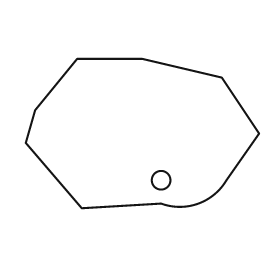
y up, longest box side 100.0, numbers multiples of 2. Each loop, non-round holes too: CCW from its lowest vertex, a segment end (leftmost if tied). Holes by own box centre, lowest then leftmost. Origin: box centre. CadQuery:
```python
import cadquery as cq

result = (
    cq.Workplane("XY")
    .moveTo(-26.0, -32.0)
    .lineTo(8.0, -30.0)
    .threePointArc((24.0, -30.0), (36.0, -20.0))
    .lineTo(50.0, 0.0)
    .lineTo(34.0, 24.0)
    .lineTo(0.0, 32.0)
    .lineTo(-28.0, 32.0)
    .lineTo(-46.0, 10.0)
    .lineTo(-50.0, -4.0)
    .close()
    .moveTo(8.0, -20.0)
    .circle(4.0)
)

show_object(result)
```